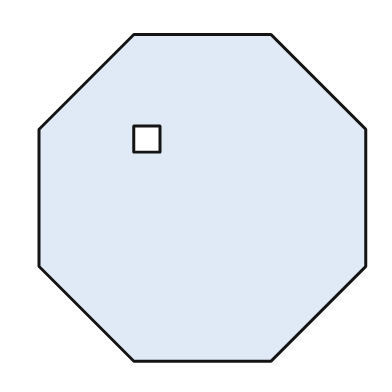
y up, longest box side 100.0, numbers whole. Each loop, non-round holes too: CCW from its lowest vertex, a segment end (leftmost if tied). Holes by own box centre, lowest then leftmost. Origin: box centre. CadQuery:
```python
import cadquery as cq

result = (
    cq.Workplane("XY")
    .moveTo(-21.0, -50.0)
    .lineTo(21.0, -50.0)
    .lineTo(50.0, -21.0)
    .lineTo(50.0, 21.0)
    .lineTo(21.0, 50.0)
    .lineTo(-21.0, 50.0)
    .lineTo(-50.0, 21.0)
    .lineTo(-50.0, -21.0)
    .close()
    .moveTo(-21.0, 14.0)
    .lineTo(-13.0, 14.0)
    .lineTo(-13.0, 22.0)
    .lineTo(-21.0, 22.0)
    .close()
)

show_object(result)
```